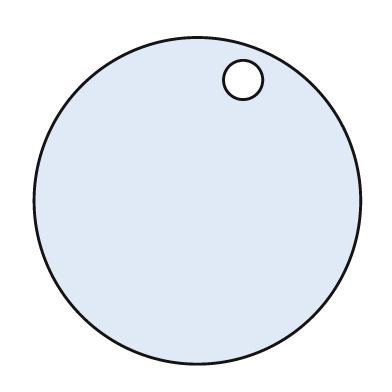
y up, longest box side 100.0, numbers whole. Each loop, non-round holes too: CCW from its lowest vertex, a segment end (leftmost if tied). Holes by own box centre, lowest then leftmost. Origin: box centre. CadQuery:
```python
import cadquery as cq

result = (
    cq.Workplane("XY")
    .moveTo(0.0, 0.0)
    .circle(50.0)
    .moveTo(14.0, 37.0)
    .circle(6.0)
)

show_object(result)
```